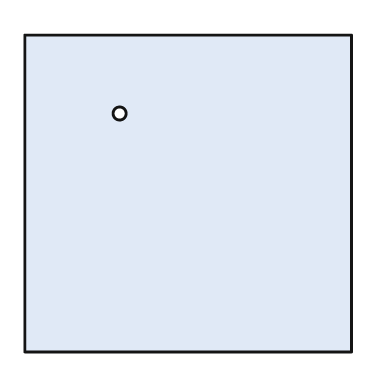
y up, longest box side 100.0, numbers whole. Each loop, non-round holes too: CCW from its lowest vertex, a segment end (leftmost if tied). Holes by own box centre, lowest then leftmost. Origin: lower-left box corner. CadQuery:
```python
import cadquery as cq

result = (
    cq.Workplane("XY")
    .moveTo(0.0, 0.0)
    .lineTo(100.0, 0.0)
    .lineTo(100.0, 97.0)
    .lineTo(0.0, 97.0)
    .close()
    .moveTo(29.0, 73.0)
    .circle(2.0)
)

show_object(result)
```